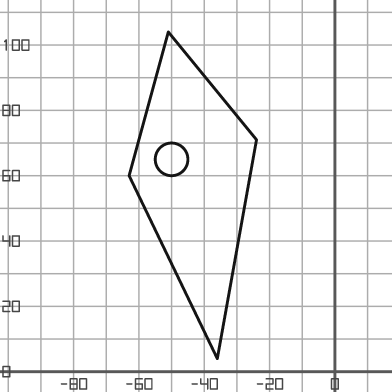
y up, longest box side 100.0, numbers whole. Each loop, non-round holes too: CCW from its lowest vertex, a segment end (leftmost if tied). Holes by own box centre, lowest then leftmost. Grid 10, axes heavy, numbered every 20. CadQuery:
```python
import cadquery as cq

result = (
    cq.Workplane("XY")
    .moveTo(-36.0, 4.0)
    .lineTo(-24.0, 71.0)
    .lineTo(-51.0, 104.0)
    .lineTo(-63.0, 60.0)
    .close()
    .moveTo(-50.0, 65.0)
    .circle(5.0)
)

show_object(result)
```